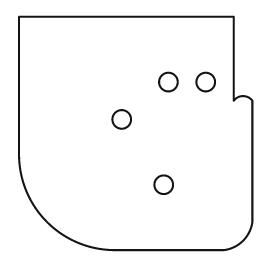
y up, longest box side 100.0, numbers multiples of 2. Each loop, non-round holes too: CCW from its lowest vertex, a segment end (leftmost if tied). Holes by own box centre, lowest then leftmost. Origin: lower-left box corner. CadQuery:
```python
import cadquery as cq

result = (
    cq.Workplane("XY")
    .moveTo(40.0, 0.0)
    .lineTo(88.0, 0.0)
    .threePointArc((96.0, 4.0), (100.0, 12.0))
    .lineTo(100.0, 64.0)
    .threePointArc((96.0, 66.0), (92.0, 64.0))
    .lineTo(92.0, 100.0)
    .lineTo(0.0, 100.0)
    .lineTo(0.0, 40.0)
    .threePointArc((12.0, 12.0), (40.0, 0.0))
    .close()
    .moveTo(62.0, 28.0)
    .circle(4.0)
    .moveTo(44.0, 56.0)
    .circle(4.0)
    .moveTo(64.0, 72.0)
    .circle(4.0)
    .moveTo(80.0, 72.0)
    .circle(4.0)
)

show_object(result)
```